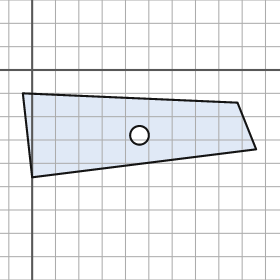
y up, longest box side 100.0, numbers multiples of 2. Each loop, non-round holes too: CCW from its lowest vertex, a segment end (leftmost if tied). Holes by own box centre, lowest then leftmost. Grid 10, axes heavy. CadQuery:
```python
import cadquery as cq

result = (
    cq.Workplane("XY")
    .moveTo(0.0, -46.0)
    .lineTo(96.0, -34.0)
    .lineTo(88.0, -14.0)
    .lineTo(-4.0, -10.0)
    .close()
    .moveTo(46.0, -28.0)
    .circle(4.0)
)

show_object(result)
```